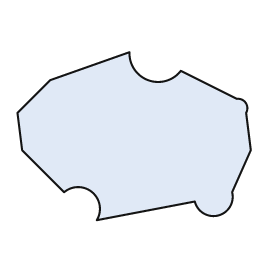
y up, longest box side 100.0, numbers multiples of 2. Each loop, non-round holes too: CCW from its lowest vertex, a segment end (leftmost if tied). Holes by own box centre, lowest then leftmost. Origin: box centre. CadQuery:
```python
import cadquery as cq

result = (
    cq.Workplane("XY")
    .moveTo(-16.0, -36.0)
    .lineTo(26.0, -28.0)
    .threePointArc((36.0, -34.0), (42.0, -24.0))
    .lineTo(50.0, -6.0)
    .lineTo(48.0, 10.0)
    .threePointArc((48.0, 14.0), (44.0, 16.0))
    .lineTo(20.0, 28.0)
    .threePointArc((6.0, 24.0), (-2.0, 36.0))
    .lineTo(-36.0, 24.0)
    .lineTo(-50.0, 10.0)
    .lineTo(-48.0, -6.0)
    .lineTo(-30.0, -24.0)
    .threePointArc((-18.0, -24.0), (-16.0, -36.0))
    .close()
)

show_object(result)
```